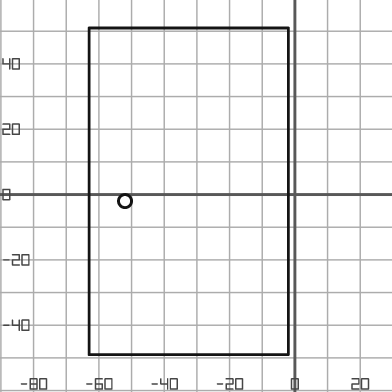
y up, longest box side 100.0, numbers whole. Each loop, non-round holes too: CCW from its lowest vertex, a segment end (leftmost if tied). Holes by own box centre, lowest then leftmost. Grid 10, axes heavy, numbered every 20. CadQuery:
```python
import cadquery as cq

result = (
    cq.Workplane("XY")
    .moveTo(-63.0, -49.0)
    .lineTo(-2.0, -49.0)
    .lineTo(-2.0, 51.0)
    .lineTo(-63.0, 51.0)
    .close()
    .moveTo(-52.0, -2.0)
    .circle(2.0)
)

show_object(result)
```